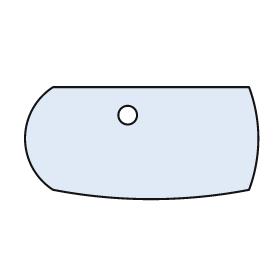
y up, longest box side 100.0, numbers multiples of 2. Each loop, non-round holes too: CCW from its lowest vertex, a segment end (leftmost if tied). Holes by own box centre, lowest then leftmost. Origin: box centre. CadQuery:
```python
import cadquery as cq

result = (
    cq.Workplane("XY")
    .moveTo(-38.0, -20.0)
    .threePointArc((4.0, -24.0), (46.0, -20.0))
    .threePointArc((50.0, 2.0), (46.0, 24.0))
    .lineTo(-38.0, 24.0)
    .threePointArc((-50.0, 2.0), (-38.0, -20.0))
    .close()
    .moveTo(-6.0, 12.0)
    .circle(4.0)
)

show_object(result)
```